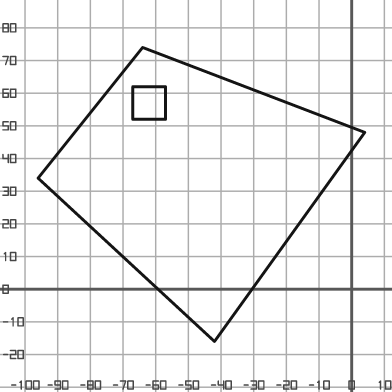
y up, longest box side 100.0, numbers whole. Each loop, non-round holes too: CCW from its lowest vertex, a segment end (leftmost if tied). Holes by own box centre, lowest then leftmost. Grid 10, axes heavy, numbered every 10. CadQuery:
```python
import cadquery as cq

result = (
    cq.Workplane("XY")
    .moveTo(-42.0, -16.0)
    .lineTo(4.0, 48.0)
    .lineTo(-64.0, 74.0)
    .lineTo(-96.0, 34.0)
    .close()
    .moveTo(-67.0, 52.0)
    .lineTo(-57.0, 52.0)
    .lineTo(-57.0, 62.0)
    .lineTo(-67.0, 62.0)
    .close()
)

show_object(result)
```